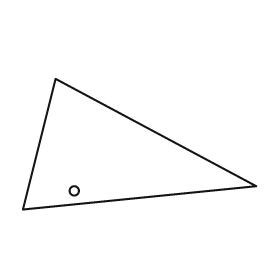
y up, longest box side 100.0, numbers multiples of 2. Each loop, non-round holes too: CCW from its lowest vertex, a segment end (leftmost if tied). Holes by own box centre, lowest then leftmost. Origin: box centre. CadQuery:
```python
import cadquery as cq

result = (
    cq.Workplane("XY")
    .moveTo(-50.0, -28.0)
    .lineTo(50.0, -18.0)
    .lineTo(-36.0, 28.0)
    .close()
    .moveTo(-28.0, -20.0)
    .circle(2.0)
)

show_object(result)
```